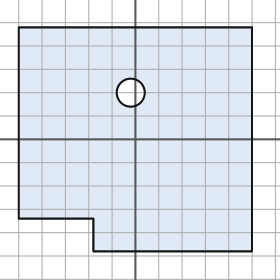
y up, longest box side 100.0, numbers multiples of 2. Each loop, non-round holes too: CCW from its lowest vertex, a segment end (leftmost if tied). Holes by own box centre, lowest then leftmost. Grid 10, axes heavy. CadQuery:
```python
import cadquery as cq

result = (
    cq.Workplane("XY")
    .moveTo(-18.0, -48.0)
    .lineTo(50.0, -48.0)
    .lineTo(50.0, 48.0)
    .lineTo(-50.0, 48.0)
    .lineTo(-50.0, -34.0)
    .lineTo(-18.0, -34.0)
    .close()
    .moveTo(-2.0, 20.0)
    .circle(6.0)
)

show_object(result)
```